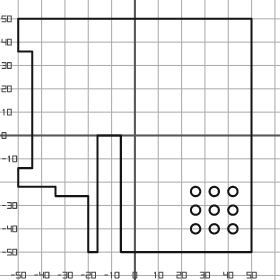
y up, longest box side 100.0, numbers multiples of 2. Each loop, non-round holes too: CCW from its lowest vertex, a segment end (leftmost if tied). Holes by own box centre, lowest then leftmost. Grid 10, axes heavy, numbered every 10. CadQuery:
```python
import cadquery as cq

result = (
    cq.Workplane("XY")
    .moveTo(-20.0, -50.0)
    .lineTo(-16.0, -50.0)
    .lineTo(-16.0, 0.0)
    .lineTo(-6.0, 0.0)
    .lineTo(-6.0, -50.0)
    .lineTo(50.0, -50.0)
    .lineTo(50.0, 50.0)
    .lineTo(-50.0, 50.0)
    .lineTo(-50.0, 36.0)
    .lineTo(-44.0, 36.0)
    .lineTo(-44.0, -14.0)
    .lineTo(-50.0, -14.0)
    .lineTo(-50.0, -22.0)
    .lineTo(-34.0, -22.0)
    .lineTo(-34.0, -26.0)
    .lineTo(-20.0, -26.0)
    .close()
    .moveTo(26.0, -40.0)
    .circle(2.0)
    .moveTo(34.0, -40.0)
    .circle(2.0)
    .moveTo(42.0, -40.0)
    .circle(2.0)
    .moveTo(26.0, -32.0)
    .circle(2.0)
    .moveTo(34.0, -32.0)
    .circle(2.0)
    .moveTo(42.0, -32.0)
    .circle(2.0)
    .moveTo(26.0, -24.0)
    .circle(2.0)
    .moveTo(34.0, -24.0)
    .circle(2.0)
    .moveTo(42.0, -24.0)
    .circle(2.0)
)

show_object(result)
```